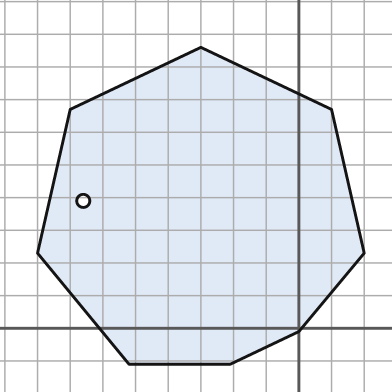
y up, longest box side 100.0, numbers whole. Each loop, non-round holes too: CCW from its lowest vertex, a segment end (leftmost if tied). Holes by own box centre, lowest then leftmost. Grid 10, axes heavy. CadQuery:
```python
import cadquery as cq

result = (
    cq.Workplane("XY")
    .moveTo(-52.0, -11.0)
    .lineTo(-21.0, -11.0)
    .lineTo(0.0, -1.0)
    .lineTo(20.0, 23.0)
    .lineTo(10.0, 67.0)
    .lineTo(-30.0, 86.0)
    .lineTo(-70.0, 67.0)
    .lineTo(-80.0, 23.0)
    .close()
    .moveTo(-66.0, 39.0)
    .circle(2.0)
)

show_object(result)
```